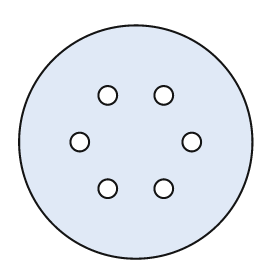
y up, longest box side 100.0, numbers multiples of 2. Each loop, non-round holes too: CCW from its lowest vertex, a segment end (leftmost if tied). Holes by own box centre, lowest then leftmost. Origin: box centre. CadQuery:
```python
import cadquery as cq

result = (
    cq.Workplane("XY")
    .moveTo(0.0, 0.0)
    .circle(50.0)
    .moveTo(-12.0, -20.0)
    .circle(4.0)
    .moveTo(12.0, -20.0)
    .circle(4.0)
    .moveTo(-24.0, 0.0)
    .circle(4.0)
    .moveTo(24.0, 0.0)
    .circle(4.0)
    .moveTo(-12.0, 20.0)
    .circle(4.0)
    .moveTo(12.0, 20.0)
    .circle(4.0)
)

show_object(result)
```